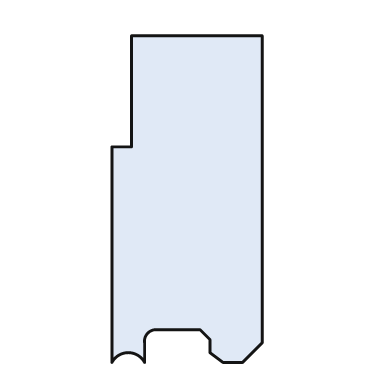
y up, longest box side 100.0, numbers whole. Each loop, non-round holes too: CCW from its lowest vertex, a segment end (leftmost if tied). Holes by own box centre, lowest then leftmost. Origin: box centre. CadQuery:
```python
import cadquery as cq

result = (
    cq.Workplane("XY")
    .moveTo(-23.0, -50.0)
    .threePointArc((-18.0, -47.0), (-13.0, -50.0))
    .lineTo(-13.0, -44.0)
    .threePointArc((-12.0, -41.0), (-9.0, -40.0))
    .lineTo(4.0, -40.0)
    .lineTo(7.0, -43.0)
    .lineTo(7.0, -47.0)
    .lineTo(11.0, -50.0)
    .lineTo(17.0, -50.0)
    .lineTo(23.0, -44.0)
    .lineTo(23.0, 50.0)
    .lineTo(-17.0, 50.0)
    .lineTo(-17.0, 16.0)
    .lineTo(-23.0, 16.0)
    .close()
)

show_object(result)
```